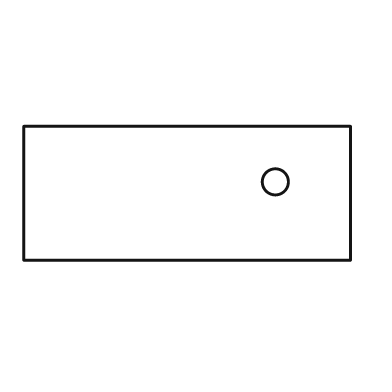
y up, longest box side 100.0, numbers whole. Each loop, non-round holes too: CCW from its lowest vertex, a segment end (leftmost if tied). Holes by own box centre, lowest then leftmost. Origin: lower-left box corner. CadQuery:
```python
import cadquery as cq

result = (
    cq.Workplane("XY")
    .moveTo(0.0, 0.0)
    .lineTo(100.0, 0.0)
    .lineTo(100.0, 41.0)
    .lineTo(0.0, 41.0)
    .close()
    .moveTo(77.0, 24.0)
    .circle(4.0)
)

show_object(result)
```